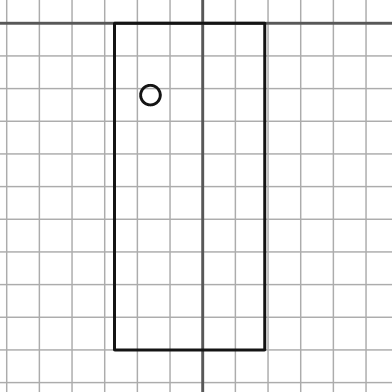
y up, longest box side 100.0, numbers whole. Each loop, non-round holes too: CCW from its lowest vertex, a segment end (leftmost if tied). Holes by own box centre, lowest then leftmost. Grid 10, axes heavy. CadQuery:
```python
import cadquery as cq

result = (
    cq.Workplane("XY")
    .moveTo(-27.0, -100.0)
    .lineTo(19.0, -100.0)
    .lineTo(19.0, 0.0)
    .lineTo(-27.0, 0.0)
    .close()
    .moveTo(-16.0, -22.0)
    .circle(3.0)
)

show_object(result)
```